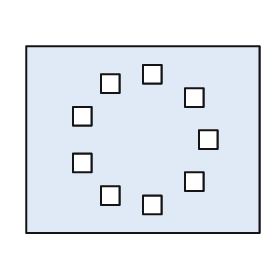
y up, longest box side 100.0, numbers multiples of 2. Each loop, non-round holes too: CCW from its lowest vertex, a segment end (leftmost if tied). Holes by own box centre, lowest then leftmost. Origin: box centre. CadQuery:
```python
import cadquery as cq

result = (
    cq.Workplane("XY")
    .moveTo(-50.0, -40.0)
    .lineTo(50.0, -40.0)
    .lineTo(50.0, 40.0)
    .lineTo(-50.0, 40.0)
    .close()
    .moveTo(0.0, -32.0)
    .lineTo(8.0, -32.0)
    .lineTo(8.0, -24.0)
    .lineTo(0.0, -24.0)
    .close()
    .moveTo(-18.0, -28.0)
    .lineTo(-10.0, -28.0)
    .lineTo(-10.0, -20.0)
    .lineTo(-18.0, -20.0)
    .close()
    .moveTo(18.0, -22.0)
    .lineTo(26.0, -22.0)
    .lineTo(26.0, -14.0)
    .lineTo(18.0, -14.0)
    .close()
    .moveTo(-30.0, -14.0)
    .lineTo(-22.0, -14.0)
    .lineTo(-22.0, -6.0)
    .lineTo(-30.0, -6.0)
    .close()
    .moveTo(24.0, -4.0)
    .lineTo(32.0, -4.0)
    .lineTo(32.0, 4.0)
    .lineTo(24.0, 4.0)
    .close()
    .moveTo(-30.0, 6.0)
    .lineTo(-22.0, 6.0)
    .lineTo(-22.0, 14.0)
    .lineTo(-30.0, 14.0)
    .close()
    .moveTo(18.0, 14.0)
    .lineTo(26.0, 14.0)
    .lineTo(26.0, 22.0)
    .lineTo(18.0, 22.0)
    .close()
    .moveTo(-18.0, 20.0)
    .lineTo(-10.0, 20.0)
    .lineTo(-10.0, 28.0)
    .lineTo(-18.0, 28.0)
    .close()
    .moveTo(0.0, 24.0)
    .lineTo(8.0, 24.0)
    .lineTo(8.0, 32.0)
    .lineTo(0.0, 32.0)
    .close()
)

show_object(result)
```